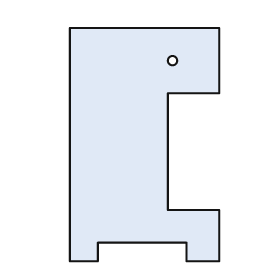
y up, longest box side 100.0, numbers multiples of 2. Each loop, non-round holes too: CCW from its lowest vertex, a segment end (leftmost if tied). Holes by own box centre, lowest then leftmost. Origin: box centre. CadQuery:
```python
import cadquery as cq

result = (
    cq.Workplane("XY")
    .moveTo(-32.0, -50.0)
    .lineTo(-20.0, -50.0)
    .lineTo(-20.0, -42.0)
    .lineTo(18.0, -42.0)
    .lineTo(18.0, -50.0)
    .lineTo(32.0, -50.0)
    .lineTo(32.0, -28.0)
    .lineTo(10.0, -28.0)
    .lineTo(10.0, 22.0)
    .lineTo(32.0, 22.0)
    .lineTo(32.0, 50.0)
    .lineTo(-32.0, 50.0)
    .close()
    .moveTo(12.0, 36.0)
    .circle(2.0)
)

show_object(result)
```